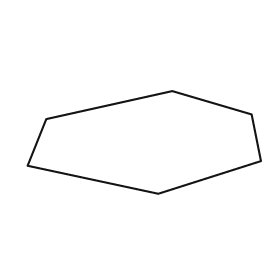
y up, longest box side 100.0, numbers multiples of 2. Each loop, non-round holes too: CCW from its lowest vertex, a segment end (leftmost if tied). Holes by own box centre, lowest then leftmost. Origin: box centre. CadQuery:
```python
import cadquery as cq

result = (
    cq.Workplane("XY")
    .moveTo(6.0, -22.0)
    .lineTo(50.0, -8.0)
    .lineTo(46.0, 12.0)
    .lineTo(12.0, 22.0)
    .lineTo(-42.0, 10.0)
    .lineTo(-50.0, -10.0)
    .close()
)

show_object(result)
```